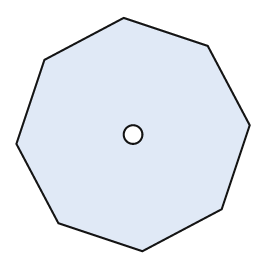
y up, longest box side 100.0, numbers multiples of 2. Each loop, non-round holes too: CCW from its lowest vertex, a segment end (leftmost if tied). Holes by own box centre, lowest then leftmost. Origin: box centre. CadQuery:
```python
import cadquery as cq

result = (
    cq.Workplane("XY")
    .moveTo(4.0, -50.0)
    .lineTo(38.0, -32.0)
    .lineTo(50.0, 4.0)
    .lineTo(32.0, 38.0)
    .lineTo(-4.0, 50.0)
    .lineTo(-38.0, 32.0)
    .lineTo(-50.0, -4.0)
    .lineTo(-32.0, -38.0)
    .close()
    .moveTo(0.0, 0.0)
    .circle(4.0)
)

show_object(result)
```